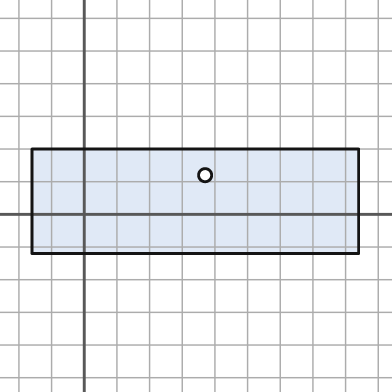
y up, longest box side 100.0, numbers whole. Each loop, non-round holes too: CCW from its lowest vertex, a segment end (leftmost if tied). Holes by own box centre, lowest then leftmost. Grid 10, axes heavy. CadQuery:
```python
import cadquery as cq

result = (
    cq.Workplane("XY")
    .moveTo(-16.0, -12.0)
    .lineTo(84.0, -12.0)
    .lineTo(84.0, 20.0)
    .lineTo(-16.0, 20.0)
    .close()
    .moveTo(37.0, 12.0)
    .circle(2.0)
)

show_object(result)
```